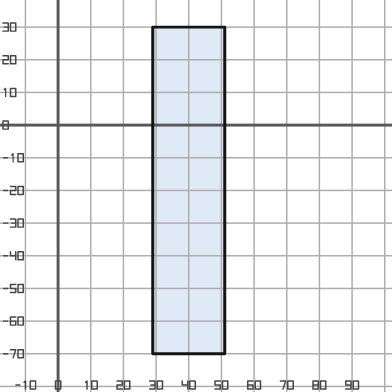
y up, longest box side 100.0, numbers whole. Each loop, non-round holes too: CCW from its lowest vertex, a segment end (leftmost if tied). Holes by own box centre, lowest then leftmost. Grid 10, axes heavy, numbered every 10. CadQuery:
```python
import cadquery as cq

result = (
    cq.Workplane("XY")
    .moveTo(29.0, -70.0)
    .lineTo(51.0, -70.0)
    .lineTo(51.0, 30.0)
    .lineTo(29.0, 30.0)
    .close()
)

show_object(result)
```